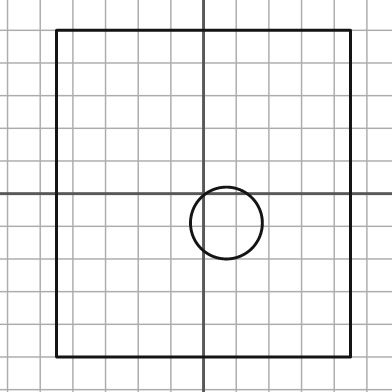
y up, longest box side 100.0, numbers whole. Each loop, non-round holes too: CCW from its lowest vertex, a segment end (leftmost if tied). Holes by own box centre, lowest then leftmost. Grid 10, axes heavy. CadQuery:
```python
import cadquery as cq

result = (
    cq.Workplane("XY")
    .moveTo(-45.0, -50.0)
    .lineTo(45.0, -50.0)
    .lineTo(45.0, 50.0)
    .lineTo(-45.0, 50.0)
    .close()
    .moveTo(7.0, -9.0)
    .circle(11.0)
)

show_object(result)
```